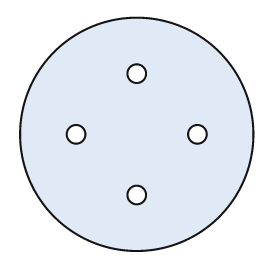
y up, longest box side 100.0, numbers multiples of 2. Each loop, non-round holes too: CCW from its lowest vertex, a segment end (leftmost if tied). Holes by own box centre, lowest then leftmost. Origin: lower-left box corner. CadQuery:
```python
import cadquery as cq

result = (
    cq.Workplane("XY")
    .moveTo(50.0, 50.0)
    .circle(50.0)
    .moveTo(50.0, 24.0)
    .circle(4.0)
    .moveTo(24.0, 50.0)
    .circle(4.0)
    .moveTo(76.0, 50.0)
    .circle(4.0)
    .moveTo(50.0, 76.0)
    .circle(4.0)
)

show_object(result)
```